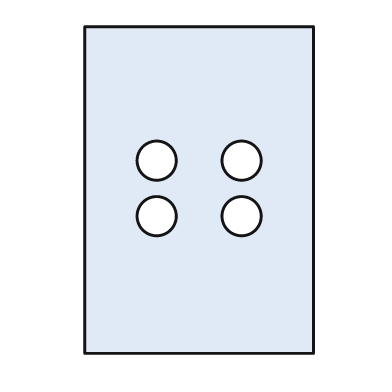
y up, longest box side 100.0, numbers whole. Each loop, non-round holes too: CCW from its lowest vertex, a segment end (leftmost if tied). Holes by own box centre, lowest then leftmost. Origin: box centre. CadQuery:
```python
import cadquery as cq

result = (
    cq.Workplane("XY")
    .moveTo(-35.0, -50.0)
    .lineTo(35.0, -50.0)
    .lineTo(35.0, 50.0)
    .lineTo(-35.0, 50.0)
    .close()
    .moveTo(-13.0, -8.0)
    .circle(6.0)
    .moveTo(13.0, -8.0)
    .circle(6.0)
    .moveTo(-13.0, 9.0)
    .circle(6.0)
    .moveTo(13.0, 9.0)
    .circle(6.0)
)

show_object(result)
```